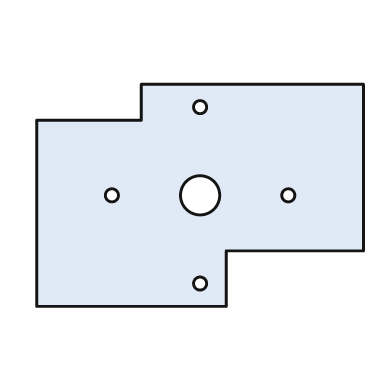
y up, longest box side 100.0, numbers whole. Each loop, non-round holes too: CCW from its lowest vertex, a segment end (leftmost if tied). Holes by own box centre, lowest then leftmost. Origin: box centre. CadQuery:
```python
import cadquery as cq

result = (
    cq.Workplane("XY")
    .moveTo(-50.0, -34.0)
    .lineTo(8.0, -34.0)
    .lineTo(8.0, -17.0)
    .lineTo(50.0, -17.0)
    .lineTo(50.0, 34.0)
    .lineTo(-18.0, 34.0)
    .lineTo(-18.0, 23.0)
    .lineTo(-50.0, 23.0)
    .close()
    .moveTo(0.0, -27.0)
    .circle(2.0)
    .moveTo(-27.0, 0.0)
    .circle(2.0)
    .moveTo(0.0, 0.0)
    .circle(6.0)
    .moveTo(27.0, 0.0)
    .circle(2.0)
    .moveTo(0.0, 27.0)
    .circle(2.0)
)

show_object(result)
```